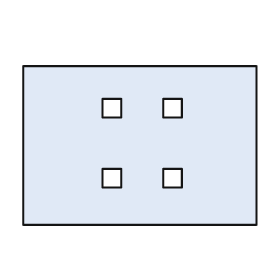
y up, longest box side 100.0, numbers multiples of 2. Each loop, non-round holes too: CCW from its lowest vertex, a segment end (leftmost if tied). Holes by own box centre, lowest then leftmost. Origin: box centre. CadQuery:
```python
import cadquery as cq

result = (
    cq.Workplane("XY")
    .moveTo(-50.0, -34.0)
    .lineTo(50.0, -34.0)
    .lineTo(50.0, 34.0)
    .lineTo(-50.0, 34.0)
    .close()
    .moveTo(-16.0, -18.0)
    .lineTo(-8.0, -18.0)
    .lineTo(-8.0, -10.0)
    .lineTo(-16.0, -10.0)
    .close()
    .moveTo(10.0, -18.0)
    .lineTo(18.0, -18.0)
    .lineTo(18.0, -10.0)
    .lineTo(10.0, -10.0)
    .close()
    .moveTo(-16.0, 12.0)
    .lineTo(-8.0, 12.0)
    .lineTo(-8.0, 20.0)
    .lineTo(-16.0, 20.0)
    .close()
    .moveTo(10.0, 12.0)
    .lineTo(18.0, 12.0)
    .lineTo(18.0, 20.0)
    .lineTo(10.0, 20.0)
    .close()
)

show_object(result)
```